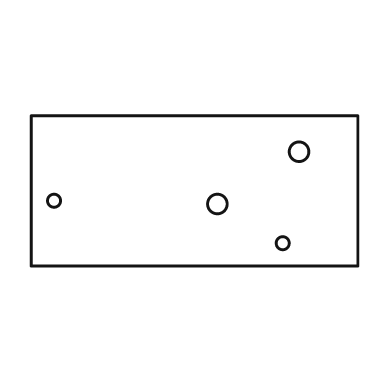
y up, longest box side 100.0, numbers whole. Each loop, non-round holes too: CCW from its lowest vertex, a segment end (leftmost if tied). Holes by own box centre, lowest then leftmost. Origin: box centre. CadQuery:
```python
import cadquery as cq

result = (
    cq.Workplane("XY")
    .moveTo(-50.0, -23.0)
    .lineTo(50.0, -23.0)
    .lineTo(50.0, 23.0)
    .lineTo(-50.0, 23.0)
    .close()
    .moveTo(27.0, -16.0)
    .circle(2.0)
    .moveTo(7.0, -4.0)
    .circle(3.0)
    .moveTo(-43.0, -3.0)
    .circle(2.0)
    .moveTo(32.0, 12.0)
    .circle(3.0)
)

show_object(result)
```